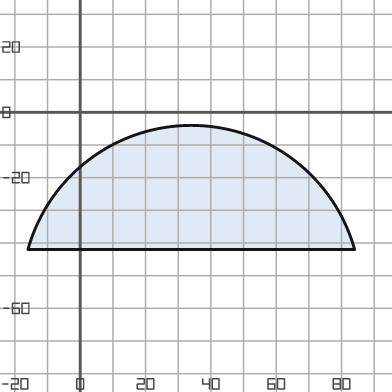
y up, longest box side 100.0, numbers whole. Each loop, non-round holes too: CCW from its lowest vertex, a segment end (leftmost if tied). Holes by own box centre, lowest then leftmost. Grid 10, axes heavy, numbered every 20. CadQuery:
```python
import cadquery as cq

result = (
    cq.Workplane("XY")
    .moveTo(-16.0, -42.0)
    .lineTo(84.0, -42.0)
    .threePointArc((34.0, -4.0), (-16.0, -42.0))
    .close()
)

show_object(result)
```